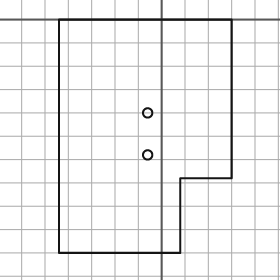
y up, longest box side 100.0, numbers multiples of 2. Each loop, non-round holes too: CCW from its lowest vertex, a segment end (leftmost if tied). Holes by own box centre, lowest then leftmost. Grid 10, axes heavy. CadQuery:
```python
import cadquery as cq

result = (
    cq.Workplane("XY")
    .moveTo(-44.0, -100.0)
    .lineTo(8.0, -100.0)
    .lineTo(8.0, -68.0)
    .lineTo(30.0, -68.0)
    .lineTo(30.0, 0.0)
    .lineTo(-44.0, 0.0)
    .close()
    .moveTo(-6.0, -58.0)
    .circle(2.0)
    .moveTo(-6.0, -40.0)
    .circle(2.0)
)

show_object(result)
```